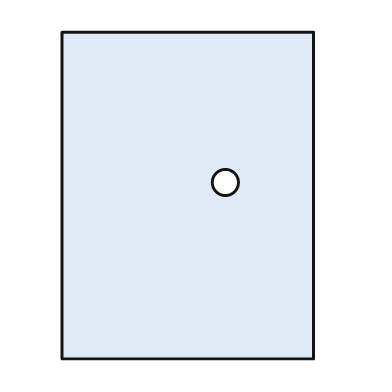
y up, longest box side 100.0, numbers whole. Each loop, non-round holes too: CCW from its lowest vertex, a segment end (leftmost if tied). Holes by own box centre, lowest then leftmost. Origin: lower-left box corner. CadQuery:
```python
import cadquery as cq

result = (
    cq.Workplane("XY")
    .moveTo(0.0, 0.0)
    .lineTo(77.0, 0.0)
    .lineTo(77.0, 100.0)
    .lineTo(0.0, 100.0)
    .close()
    .moveTo(50.0, 54.0)
    .circle(4.0)
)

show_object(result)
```